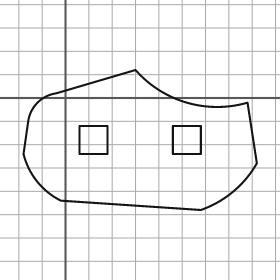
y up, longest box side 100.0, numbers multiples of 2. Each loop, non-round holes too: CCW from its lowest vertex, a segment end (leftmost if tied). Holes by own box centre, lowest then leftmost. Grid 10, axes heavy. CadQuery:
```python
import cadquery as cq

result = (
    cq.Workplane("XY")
    .moveTo(58.0, -48.0)
    .threePointArc((72.0, -40.0), (82.0, -28.0))
    .lineTo(78.0, -2.0)
    .threePointArc((52.0, -2.0), (30.0, 12.0))
    .lineTo(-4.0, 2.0)
    .threePointArc((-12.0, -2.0), (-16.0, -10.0))
    .lineTo(-18.0, -24.0)
    .threePointArc((-12.0, -36.0), (-2.0, -44.0))
    .close()
    .moveTo(6.0, -24.0)
    .lineTo(18.0, -24.0)
    .lineTo(18.0, -12.0)
    .lineTo(6.0, -12.0)
    .close()
    .moveTo(46.0, -24.0)
    .lineTo(58.0, -24.0)
    .lineTo(58.0, -12.0)
    .lineTo(46.0, -12.0)
    .close()
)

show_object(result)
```